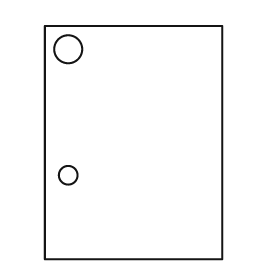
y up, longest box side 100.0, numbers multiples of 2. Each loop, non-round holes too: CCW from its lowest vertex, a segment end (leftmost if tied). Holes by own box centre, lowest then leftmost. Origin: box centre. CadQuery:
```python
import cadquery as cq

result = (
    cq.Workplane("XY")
    .moveTo(-38.0, -50.0)
    .lineTo(38.0, -50.0)
    .lineTo(38.0, 50.0)
    .lineTo(-38.0, 50.0)
    .close()
    .moveTo(-28.0, -14.0)
    .circle(4.0)
    .moveTo(-28.0, 40.0)
    .circle(6.0)
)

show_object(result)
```